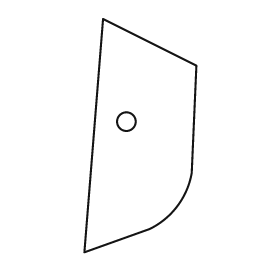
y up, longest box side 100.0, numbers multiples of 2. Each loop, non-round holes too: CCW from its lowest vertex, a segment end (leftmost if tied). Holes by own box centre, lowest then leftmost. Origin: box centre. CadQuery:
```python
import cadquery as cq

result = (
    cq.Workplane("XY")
    .moveTo(-24.0, -50.0)
    .lineTo(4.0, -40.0)
    .threePointArc((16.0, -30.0), (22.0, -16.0))
    .lineTo(24.0, 30.0)
    .lineTo(-16.0, 50.0)
    .close()
    .moveTo(-6.0, 6.0)
    .circle(4.0)
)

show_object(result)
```